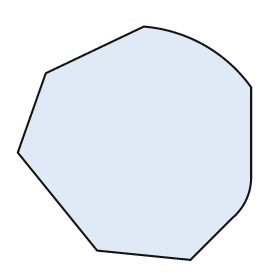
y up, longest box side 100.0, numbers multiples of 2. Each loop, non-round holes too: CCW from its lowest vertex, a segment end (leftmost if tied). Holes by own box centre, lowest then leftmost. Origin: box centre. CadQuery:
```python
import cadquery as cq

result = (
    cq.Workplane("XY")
    .moveTo(24.0, -50.0)
    .lineTo(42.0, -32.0)
    .threePointArc((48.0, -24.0), (50.0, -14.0))
    .lineTo(50.0, 24.0)
    .threePointArc((30.0, 42.0), (4.0, 50.0))
    .lineTo(-38.0, 30.0)
    .lineTo(-50.0, -4.0)
    .lineTo(-16.0, -46.0)
    .close()
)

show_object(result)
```